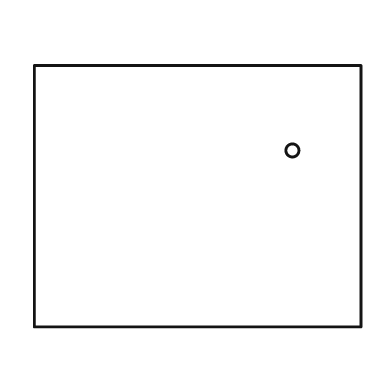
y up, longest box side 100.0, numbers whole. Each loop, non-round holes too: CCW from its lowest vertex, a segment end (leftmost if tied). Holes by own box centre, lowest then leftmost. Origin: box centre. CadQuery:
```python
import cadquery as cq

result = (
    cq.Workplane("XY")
    .moveTo(-50.0, -40.0)
    .lineTo(50.0, -40.0)
    .lineTo(50.0, 40.0)
    .lineTo(-50.0, 40.0)
    .close()
    .moveTo(29.0, 14.0)
    .circle(2.0)
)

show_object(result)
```